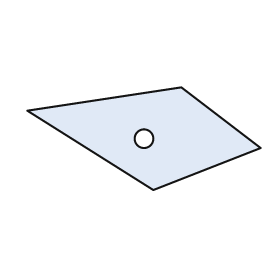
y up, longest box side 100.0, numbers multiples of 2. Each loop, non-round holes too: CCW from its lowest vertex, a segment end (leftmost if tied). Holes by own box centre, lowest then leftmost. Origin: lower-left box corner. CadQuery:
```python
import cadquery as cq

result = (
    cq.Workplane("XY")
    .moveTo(54.0, 0.0)
    .lineTo(100.0, 18.0)
    .lineTo(66.0, 44.0)
    .lineTo(0.0, 34.0)
    .close()
    .moveTo(50.0, 22.0)
    .circle(4.0)
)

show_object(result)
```